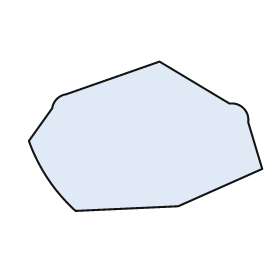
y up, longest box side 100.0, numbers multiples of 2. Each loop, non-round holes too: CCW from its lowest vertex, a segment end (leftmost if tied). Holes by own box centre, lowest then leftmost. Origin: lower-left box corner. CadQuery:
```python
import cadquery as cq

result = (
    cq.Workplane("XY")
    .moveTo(20.0, 0.0)
    .lineTo(64.0, 2.0)
    .lineTo(100.0, 18.0)
    .lineTo(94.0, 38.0)
    .threePointArc((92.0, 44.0), (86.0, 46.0))
    .lineTo(56.0, 64.0)
    .lineTo(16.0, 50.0)
    .threePointArc((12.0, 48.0), (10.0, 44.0))
    .lineTo(0.0, 30.0)
    .threePointArc((8.0, 14.0), (20.0, 0.0))
    .close()
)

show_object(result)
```